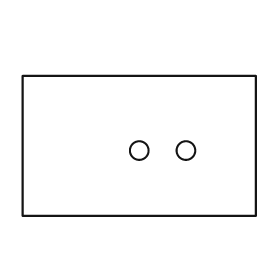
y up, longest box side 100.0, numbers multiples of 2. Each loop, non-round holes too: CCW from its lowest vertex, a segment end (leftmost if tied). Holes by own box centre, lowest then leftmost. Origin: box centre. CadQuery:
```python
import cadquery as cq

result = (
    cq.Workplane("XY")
    .moveTo(-50.0, -30.0)
    .lineTo(50.0, -30.0)
    .lineTo(50.0, 30.0)
    .lineTo(-50.0, 30.0)
    .close()
    .moveTo(0.0, -2.0)
    .circle(4.0)
    .moveTo(20.0, -2.0)
    .circle(4.0)
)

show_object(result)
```